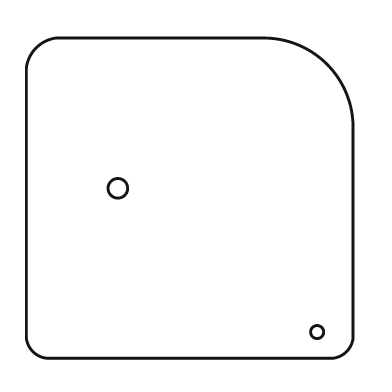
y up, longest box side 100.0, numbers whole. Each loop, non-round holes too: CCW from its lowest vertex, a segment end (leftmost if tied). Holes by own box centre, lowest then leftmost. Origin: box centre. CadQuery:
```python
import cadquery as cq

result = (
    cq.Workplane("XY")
    .moveTo(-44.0, -49.0)
    .lineTo(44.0, -49.0)
    .threePointArc((48.0, -47.0), (50.0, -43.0))
    .lineTo(50.0, 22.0)
    .threePointArc((42.0, 41.0), (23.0, 49.0))
    .lineTo(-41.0, 49.0)
    .threePointArc((-47.0, 46.0), (-50.0, 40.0))
    .lineTo(-50.0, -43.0)
    .threePointArc((-48.0, -47.0), (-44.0, -49.0))
    .close()
    .moveTo(39.0, -41.0)
    .circle(2.0)
    .moveTo(-22.0, 3.0)
    .circle(3.0)
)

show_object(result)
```